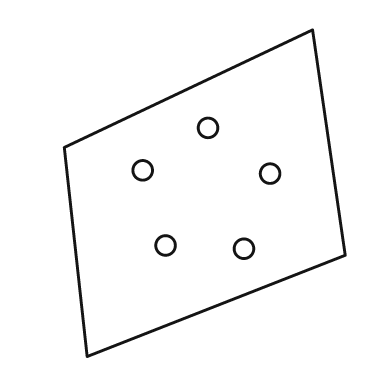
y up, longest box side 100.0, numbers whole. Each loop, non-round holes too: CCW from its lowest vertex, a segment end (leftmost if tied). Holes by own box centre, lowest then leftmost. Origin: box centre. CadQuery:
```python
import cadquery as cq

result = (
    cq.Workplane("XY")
    .moveTo(-36.0, -50.0)
    .lineTo(43.0, -19.0)
    .lineTo(33.0, 50.0)
    .lineTo(-43.0, 14.0)
    .close()
    .moveTo(12.0, -17.0)
    .circle(3.0)
    .moveTo(-12.0, -16.0)
    .circle(3.0)
    .moveTo(20.0, 6.0)
    .circle(3.0)
    .moveTo(-19.0, 7.0)
    .circle(3.0)
    .moveTo(1.0, 20.0)
    .circle(3.0)
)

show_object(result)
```